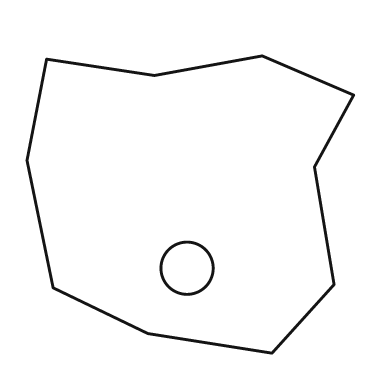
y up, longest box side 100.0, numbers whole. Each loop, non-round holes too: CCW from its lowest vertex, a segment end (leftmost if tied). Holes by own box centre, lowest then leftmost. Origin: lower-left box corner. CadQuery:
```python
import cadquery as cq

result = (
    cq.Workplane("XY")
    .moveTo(75.0, 0.0)
    .lineTo(94.0, 21.0)
    .lineTo(88.0, 57.0)
    .lineTo(100.0, 79.0)
    .lineTo(72.0, 91.0)
    .lineTo(39.0, 85.0)
    .lineTo(6.0, 90.0)
    .lineTo(0.0, 59.0)
    .lineTo(8.0, 20.0)
    .lineTo(37.0, 6.0)
    .close()
    .moveTo(49.0, 26.0)
    .circle(8.0)
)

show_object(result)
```